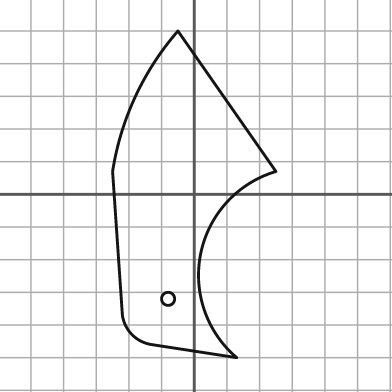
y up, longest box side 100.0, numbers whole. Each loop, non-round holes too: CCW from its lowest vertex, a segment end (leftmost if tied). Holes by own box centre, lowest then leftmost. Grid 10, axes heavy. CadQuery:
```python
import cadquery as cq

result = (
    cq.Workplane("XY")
    .moveTo(13.0, -50.0)
    .threePointArc((2.0, -18.0), (25.0, 7.0))
    .lineTo(-5.0, 50.0)
    .threePointArc((-18.0, 30.0), (-25.0, 7.0))
    .lineTo(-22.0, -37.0)
    .threePointArc((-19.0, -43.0), (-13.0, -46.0))
    .close()
    .moveTo(-8.0, -32.0)
    .circle(2.0)
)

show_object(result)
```